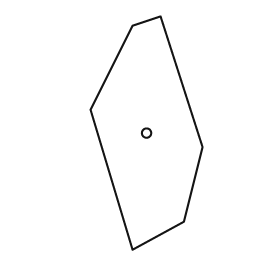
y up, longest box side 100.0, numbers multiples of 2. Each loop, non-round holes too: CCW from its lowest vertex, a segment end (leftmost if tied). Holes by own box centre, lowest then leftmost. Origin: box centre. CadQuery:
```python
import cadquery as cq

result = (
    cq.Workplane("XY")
    .moveTo(-6.0, -50.0)
    .lineTo(16.0, -38.0)
    .lineTo(24.0, -6.0)
    .lineTo(6.0, 50.0)
    .lineTo(-6.0, 46.0)
    .lineTo(-24.0, 10.0)
    .close()
    .moveTo(0.0, 0.0)
    .circle(2.0)
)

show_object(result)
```